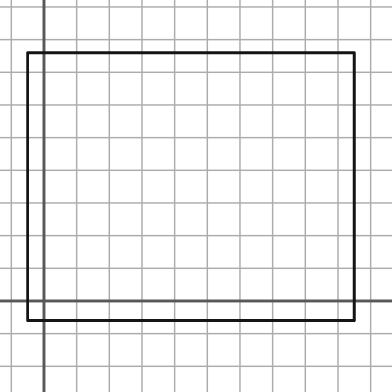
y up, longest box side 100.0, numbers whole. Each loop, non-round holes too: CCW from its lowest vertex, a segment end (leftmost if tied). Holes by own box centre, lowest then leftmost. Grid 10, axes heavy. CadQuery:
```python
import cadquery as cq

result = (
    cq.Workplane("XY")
    .moveTo(-5.0, -6.0)
    .lineTo(95.0, -6.0)
    .lineTo(95.0, 76.0)
    .lineTo(-5.0, 76.0)
    .close()
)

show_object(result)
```